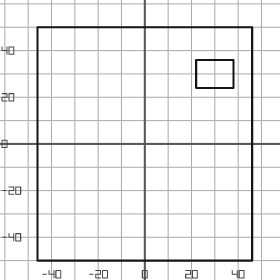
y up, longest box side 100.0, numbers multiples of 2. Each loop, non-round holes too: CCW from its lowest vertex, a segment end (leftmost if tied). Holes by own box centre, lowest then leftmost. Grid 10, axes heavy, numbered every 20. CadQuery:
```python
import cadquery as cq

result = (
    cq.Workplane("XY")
    .moveTo(-46.0, -50.0)
    .lineTo(46.0, -50.0)
    .lineTo(46.0, 50.0)
    .lineTo(-46.0, 50.0)
    .close()
    .moveTo(22.0, 24.0)
    .lineTo(38.0, 24.0)
    .lineTo(38.0, 36.0)
    .lineTo(22.0, 36.0)
    .close()
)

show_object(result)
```